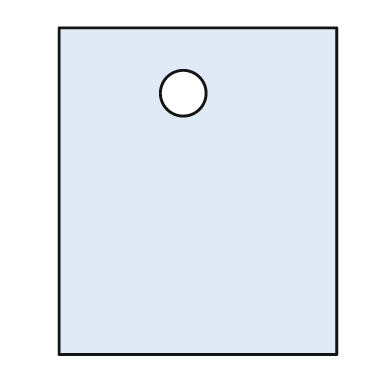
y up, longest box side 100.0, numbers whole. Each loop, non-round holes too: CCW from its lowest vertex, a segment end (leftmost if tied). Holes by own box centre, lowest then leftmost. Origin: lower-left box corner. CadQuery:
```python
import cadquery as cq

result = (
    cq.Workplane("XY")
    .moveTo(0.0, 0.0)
    .lineTo(85.0, 0.0)
    .lineTo(85.0, 100.0)
    .lineTo(0.0, 100.0)
    .close()
    .moveTo(38.0, 80.0)
    .circle(7.0)
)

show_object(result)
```